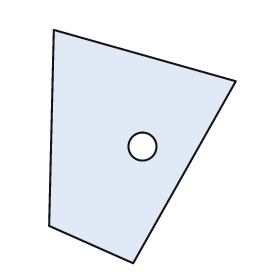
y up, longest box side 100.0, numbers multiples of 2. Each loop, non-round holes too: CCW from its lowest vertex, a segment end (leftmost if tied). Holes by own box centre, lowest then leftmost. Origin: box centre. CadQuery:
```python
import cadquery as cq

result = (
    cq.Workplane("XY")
    .moveTo(-4.0, -50.0)
    .lineTo(40.0, 28.0)
    .lineTo(-38.0, 50.0)
    .lineTo(-40.0, -34.0)
    .close()
    .moveTo(0.0, 0.0)
    .circle(6.0)
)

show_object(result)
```